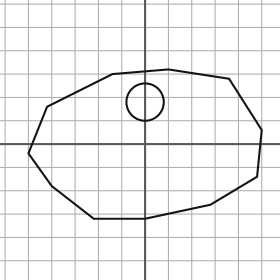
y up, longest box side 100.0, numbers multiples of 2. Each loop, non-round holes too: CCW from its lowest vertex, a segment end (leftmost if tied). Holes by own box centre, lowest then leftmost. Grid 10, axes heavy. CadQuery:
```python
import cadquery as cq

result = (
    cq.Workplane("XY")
    .moveTo(-22.0, -32.0)
    .lineTo(0.0, -32.0)
    .lineTo(28.0, -26.0)
    .lineTo(48.0, -14.0)
    .lineTo(50.0, 6.0)
    .lineTo(36.0, 28.0)
    .lineTo(10.0, 32.0)
    .lineTo(-14.0, 30.0)
    .lineTo(-42.0, 16.0)
    .lineTo(-50.0, -4.0)
    .lineTo(-40.0, -18.0)
    .close()
    .moveTo(0.0, 18.0)
    .circle(8.0)
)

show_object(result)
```